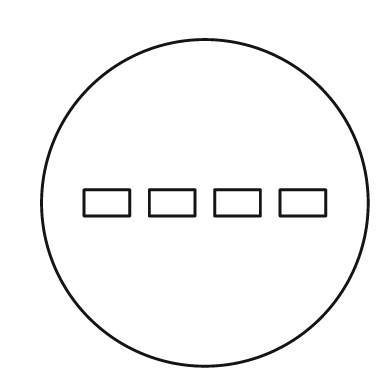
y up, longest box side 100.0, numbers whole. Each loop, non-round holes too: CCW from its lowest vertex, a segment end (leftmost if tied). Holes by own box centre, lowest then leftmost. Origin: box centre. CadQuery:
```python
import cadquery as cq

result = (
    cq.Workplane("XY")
    .moveTo(0.0, 0.0)
    .circle(50.0)
    .moveTo(-37.0, -4.0)
    .lineTo(-23.0, -4.0)
    .lineTo(-23.0, 4.0)
    .lineTo(-37.0, 4.0)
    .close()
    .moveTo(-17.0, -4.0)
    .lineTo(-3.0, -4.0)
    .lineTo(-3.0, 4.0)
    .lineTo(-17.0, 4.0)
    .close()
    .moveTo(3.0, -4.0)
    .lineTo(17.0, -4.0)
    .lineTo(17.0, 4.0)
    .lineTo(3.0, 4.0)
    .close()
    .moveTo(23.0, -4.0)
    .lineTo(37.0, -4.0)
    .lineTo(37.0, 4.0)
    .lineTo(23.0, 4.0)
    .close()
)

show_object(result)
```